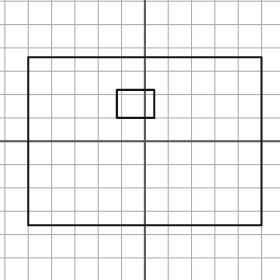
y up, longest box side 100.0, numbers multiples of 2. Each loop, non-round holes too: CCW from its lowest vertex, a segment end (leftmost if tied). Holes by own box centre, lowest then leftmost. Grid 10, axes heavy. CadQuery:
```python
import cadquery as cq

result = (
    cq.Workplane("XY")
    .moveTo(-50.0, -36.0)
    .lineTo(50.0, -36.0)
    .lineTo(50.0, 36.0)
    .lineTo(-50.0, 36.0)
    .close()
    .moveTo(-12.0, 10.0)
    .lineTo(4.0, 10.0)
    .lineTo(4.0, 22.0)
    .lineTo(-12.0, 22.0)
    .close()
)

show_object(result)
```